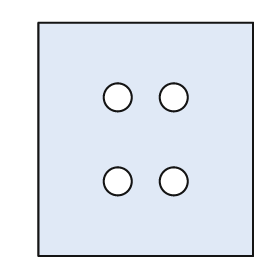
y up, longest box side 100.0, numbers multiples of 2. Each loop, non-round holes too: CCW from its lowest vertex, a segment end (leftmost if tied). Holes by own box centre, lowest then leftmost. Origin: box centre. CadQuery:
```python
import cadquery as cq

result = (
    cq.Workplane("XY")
    .moveTo(-46.0, -50.0)
    .lineTo(46.0, -50.0)
    .lineTo(46.0, 50.0)
    .lineTo(-46.0, 50.0)
    .close()
    .moveTo(-12.0, -18.0)
    .circle(6.0)
    .moveTo(12.0, -18.0)
    .circle(6.0)
    .moveTo(-12.0, 18.0)
    .circle(6.0)
    .moveTo(12.0, 18.0)
    .circle(6.0)
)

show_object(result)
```